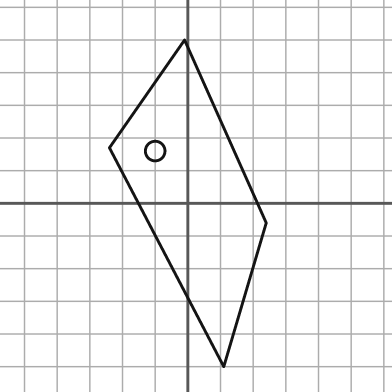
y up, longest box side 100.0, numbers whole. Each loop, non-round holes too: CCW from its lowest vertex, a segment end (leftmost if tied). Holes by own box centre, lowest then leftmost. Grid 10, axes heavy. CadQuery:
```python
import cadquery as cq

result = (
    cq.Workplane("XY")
    .moveTo(11.0, -50.0)
    .lineTo(24.0, -6.0)
    .lineTo(-1.0, 50.0)
    .lineTo(-24.0, 17.0)
    .close()
    .moveTo(-10.0, 16.0)
    .circle(3.0)
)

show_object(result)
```